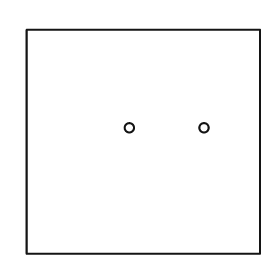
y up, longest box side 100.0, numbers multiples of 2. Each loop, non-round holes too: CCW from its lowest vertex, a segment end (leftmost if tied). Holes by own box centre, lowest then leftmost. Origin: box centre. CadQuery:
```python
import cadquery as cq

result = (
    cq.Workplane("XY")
    .moveTo(-50.0, -48.0)
    .lineTo(50.0, -48.0)
    .lineTo(50.0, 48.0)
    .lineTo(-50.0, 48.0)
    .close()
    .moveTo(-6.0, 6.0)
    .circle(2.0)
    .moveTo(26.0, 6.0)
    .circle(2.0)
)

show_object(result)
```